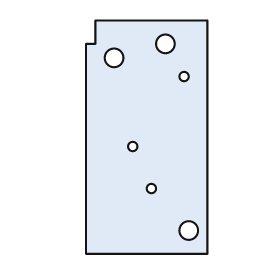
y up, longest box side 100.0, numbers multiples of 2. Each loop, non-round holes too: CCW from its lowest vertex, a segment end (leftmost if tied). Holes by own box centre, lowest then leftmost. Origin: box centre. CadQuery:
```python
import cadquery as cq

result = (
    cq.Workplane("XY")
    .moveTo(-26.0, -50.0)
    .lineTo(26.0, -50.0)
    .lineTo(26.0, 50.0)
    .lineTo(-22.0, 50.0)
    .lineTo(-22.0, 40.0)
    .lineTo(-26.0, 40.0)
    .close()
    .moveTo(18.0, -40.0)
    .circle(4.0)
    .moveTo(2.0, -22.0)
    .circle(2.0)
    .moveTo(-6.0, -4.0)
    .circle(2.0)
    .moveTo(16.0, 26.0)
    .circle(2.0)
    .moveTo(-14.0, 34.0)
    .circle(4.0)
    .moveTo(8.0, 40.0)
    .circle(4.0)
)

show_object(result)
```